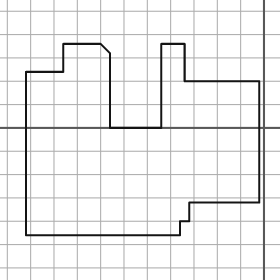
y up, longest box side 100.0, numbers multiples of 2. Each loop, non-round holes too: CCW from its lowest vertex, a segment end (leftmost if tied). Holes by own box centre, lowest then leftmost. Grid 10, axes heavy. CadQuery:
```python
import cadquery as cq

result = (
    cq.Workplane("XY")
    .moveTo(-102.0, -46.0)
    .lineTo(-36.0, -46.0)
    .lineTo(-36.0, -40.0)
    .lineTo(-32.0, -40.0)
    .lineTo(-32.0, -32.0)
    .lineTo(-2.0, -32.0)
    .lineTo(-2.0, 20.0)
    .lineTo(-34.0, 20.0)
    .lineTo(-34.0, 36.0)
    .lineTo(-44.0, 36.0)
    .lineTo(-44.0, 0.0)
    .lineTo(-66.0, 0.0)
    .lineTo(-66.0, 32.0)
    .lineTo(-70.0, 36.0)
    .lineTo(-86.0, 36.0)
    .lineTo(-86.0, 24.0)
    .lineTo(-102.0, 24.0)
    .close()
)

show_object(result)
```